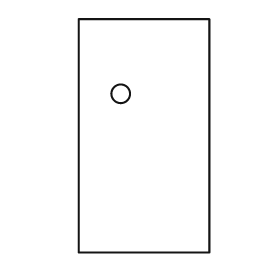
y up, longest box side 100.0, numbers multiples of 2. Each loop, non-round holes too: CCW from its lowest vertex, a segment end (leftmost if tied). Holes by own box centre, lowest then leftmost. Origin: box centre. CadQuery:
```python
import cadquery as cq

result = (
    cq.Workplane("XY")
    .moveTo(-28.0, -50.0)
    .lineTo(28.0, -50.0)
    .lineTo(28.0, 50.0)
    .lineTo(-28.0, 50.0)
    .close()
    .moveTo(-10.0, 18.0)
    .circle(4.0)
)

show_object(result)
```